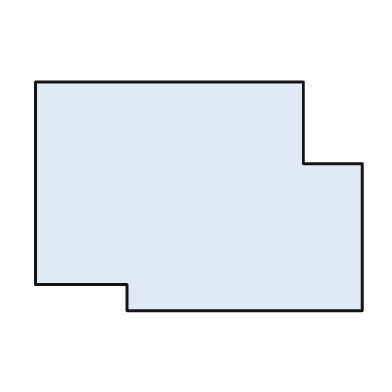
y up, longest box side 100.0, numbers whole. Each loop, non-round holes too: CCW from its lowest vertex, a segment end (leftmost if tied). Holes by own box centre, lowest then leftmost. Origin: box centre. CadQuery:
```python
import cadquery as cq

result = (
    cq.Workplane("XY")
    .moveTo(-22.0, -35.0)
    .lineTo(50.0, -35.0)
    .lineTo(50.0, 10.0)
    .lineTo(32.0, 10.0)
    .lineTo(32.0, 35.0)
    .lineTo(-50.0, 35.0)
    .lineTo(-50.0, -27.0)
    .lineTo(-22.0, -27.0)
    .close()
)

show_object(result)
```